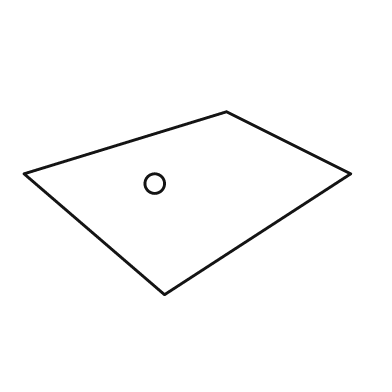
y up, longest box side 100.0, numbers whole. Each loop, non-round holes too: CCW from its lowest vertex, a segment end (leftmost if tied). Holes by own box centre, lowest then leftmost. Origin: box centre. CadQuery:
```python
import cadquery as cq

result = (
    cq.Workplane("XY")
    .moveTo(-7.0, -28.0)
    .lineTo(50.0, 9.0)
    .lineTo(12.0, 28.0)
    .lineTo(-50.0, 9.0)
    .close()
    .moveTo(-10.0, 6.0)
    .circle(3.0)
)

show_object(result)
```